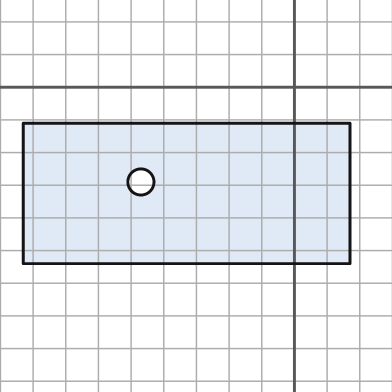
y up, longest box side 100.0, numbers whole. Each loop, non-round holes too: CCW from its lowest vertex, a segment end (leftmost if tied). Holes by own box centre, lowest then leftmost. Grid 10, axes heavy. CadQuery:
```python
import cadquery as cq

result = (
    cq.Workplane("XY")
    .moveTo(-83.0, -54.0)
    .lineTo(17.0, -54.0)
    .lineTo(17.0, -11.0)
    .lineTo(-83.0, -11.0)
    .close()
    .moveTo(-47.0, -29.0)
    .circle(4.0)
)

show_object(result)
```